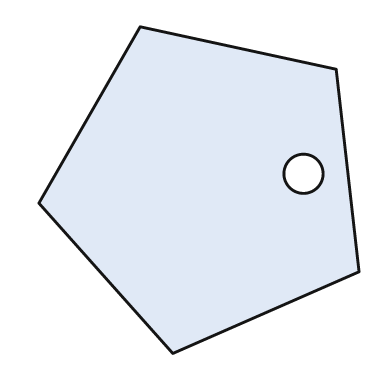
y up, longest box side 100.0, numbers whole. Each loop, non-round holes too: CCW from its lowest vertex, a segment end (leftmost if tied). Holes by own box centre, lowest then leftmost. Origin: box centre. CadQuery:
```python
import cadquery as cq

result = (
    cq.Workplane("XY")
    .moveTo(-8.0, -50.0)
    .lineTo(49.0, -25.0)
    .lineTo(42.0, 37.0)
    .lineTo(-18.0, 50.0)
    .lineTo(-49.0, -4.0)
    .close()
    .moveTo(32.0, 5.0)
    .circle(6.0)
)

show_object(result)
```